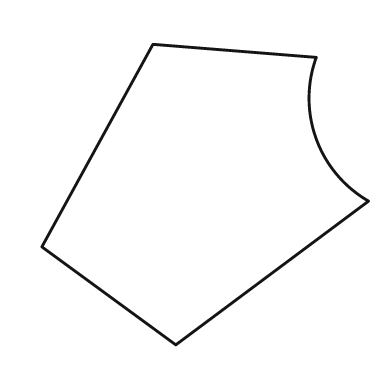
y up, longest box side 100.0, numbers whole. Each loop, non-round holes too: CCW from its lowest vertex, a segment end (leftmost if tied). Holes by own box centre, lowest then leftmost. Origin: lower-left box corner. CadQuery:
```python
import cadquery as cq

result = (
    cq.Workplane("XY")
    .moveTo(41.0, 0.0)
    .lineTo(100.0, 44.0)
    .threePointArc((84.0, 63.0), (84.0, 88.0))
    .lineTo(34.0, 92.0)
    .lineTo(0.0, 30.0)
    .close()
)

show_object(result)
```